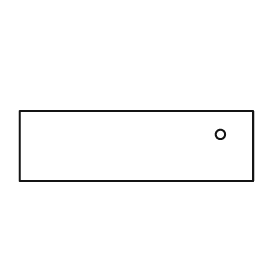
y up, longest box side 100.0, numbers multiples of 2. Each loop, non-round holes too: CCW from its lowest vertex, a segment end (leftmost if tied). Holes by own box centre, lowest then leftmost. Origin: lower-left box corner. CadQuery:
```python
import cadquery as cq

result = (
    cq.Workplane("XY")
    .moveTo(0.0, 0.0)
    .lineTo(100.0, 0.0)
    .lineTo(100.0, 30.0)
    .lineTo(0.0, 30.0)
    .close()
    .moveTo(86.0, 20.0)
    .circle(2.0)
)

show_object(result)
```